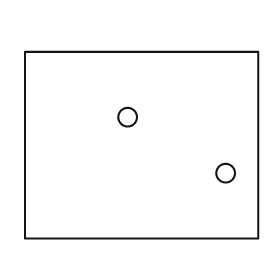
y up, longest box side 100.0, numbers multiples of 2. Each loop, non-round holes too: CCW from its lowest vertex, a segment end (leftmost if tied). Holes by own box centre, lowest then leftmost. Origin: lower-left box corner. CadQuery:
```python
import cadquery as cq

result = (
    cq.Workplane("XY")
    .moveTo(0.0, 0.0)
    .lineTo(100.0, 0.0)
    .lineTo(100.0, 80.0)
    .lineTo(0.0, 80.0)
    .close()
    .moveTo(86.0, 28.0)
    .circle(4.0)
    .moveTo(44.0, 52.0)
    .circle(4.0)
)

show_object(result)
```